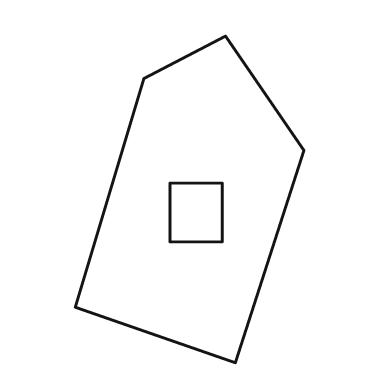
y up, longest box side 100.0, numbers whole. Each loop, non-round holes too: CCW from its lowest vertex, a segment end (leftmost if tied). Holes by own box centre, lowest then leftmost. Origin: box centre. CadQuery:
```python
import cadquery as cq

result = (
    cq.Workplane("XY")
    .moveTo(14.0, -50.0)
    .lineTo(35.0, 15.0)
    .lineTo(11.0, 50.0)
    .lineTo(-14.0, 37.0)
    .lineTo(-35.0, -33.0)
    .close()
    .moveTo(-6.0, -13.0)
    .lineTo(10.0, -13.0)
    .lineTo(10.0, 5.0)
    .lineTo(-6.0, 5.0)
    .close()
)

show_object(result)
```